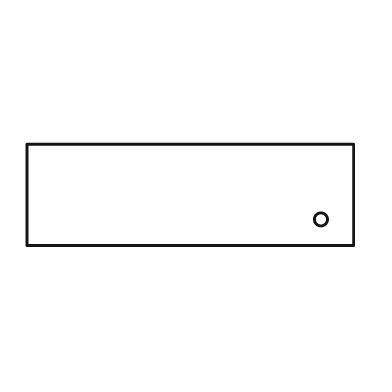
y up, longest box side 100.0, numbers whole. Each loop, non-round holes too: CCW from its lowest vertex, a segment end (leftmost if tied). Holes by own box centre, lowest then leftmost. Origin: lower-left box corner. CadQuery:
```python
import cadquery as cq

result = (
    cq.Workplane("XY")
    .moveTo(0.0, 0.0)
    .lineTo(100.0, 0.0)
    .lineTo(100.0, 31.0)
    .lineTo(0.0, 31.0)
    .close()
    .moveTo(90.0, 8.0)
    .circle(2.0)
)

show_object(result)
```